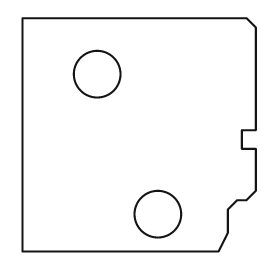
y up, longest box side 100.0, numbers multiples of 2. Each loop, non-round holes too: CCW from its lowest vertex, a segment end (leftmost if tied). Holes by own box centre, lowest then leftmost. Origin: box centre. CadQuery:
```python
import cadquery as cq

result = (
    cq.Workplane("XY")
    .moveTo(-50.0, -50.0)
    .lineTo(34.0, -50.0)
    .lineTo(38.0, -42.0)
    .lineTo(38.0, -32.0)
    .lineTo(42.0, -28.0)
    .lineTo(46.0, -28.0)
    .lineTo(50.0, -24.0)
    .lineTo(50.0, -6.0)
    .lineTo(44.0, -6.0)
    .lineTo(44.0, 2.0)
    .lineTo(50.0, 2.0)
    .lineTo(50.0, 46.0)
    .lineTo(46.0, 50.0)
    .lineTo(-50.0, 50.0)
    .close()
    .moveTo(8.0, -34.0)
    .circle(10.0)
    .moveTo(-18.0, 26.0)
    .circle(10.0)
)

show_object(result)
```